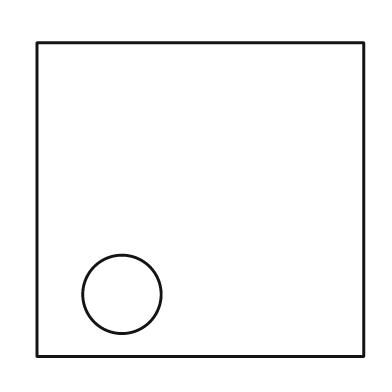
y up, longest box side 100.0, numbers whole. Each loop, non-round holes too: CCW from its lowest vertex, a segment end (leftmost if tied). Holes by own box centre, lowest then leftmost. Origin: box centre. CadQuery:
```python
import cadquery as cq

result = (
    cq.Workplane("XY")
    .moveTo(-50.0, -48.0)
    .lineTo(50.0, -48.0)
    .lineTo(50.0, 48.0)
    .lineTo(-50.0, 48.0)
    .close()
    .moveTo(-24.0, -29.0)
    .circle(12.0)
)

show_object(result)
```